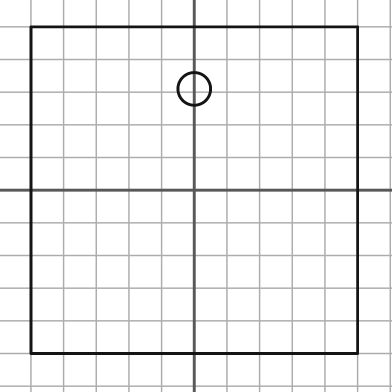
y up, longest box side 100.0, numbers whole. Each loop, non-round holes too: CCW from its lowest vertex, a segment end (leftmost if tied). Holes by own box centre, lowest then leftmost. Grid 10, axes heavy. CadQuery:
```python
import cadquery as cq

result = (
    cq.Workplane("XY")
    .moveTo(-50.0, -50.0)
    .lineTo(50.0, -50.0)
    .lineTo(50.0, 50.0)
    .lineTo(-50.0, 50.0)
    .close()
    .moveTo(0.0, 31.0)
    .circle(5.0)
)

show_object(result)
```